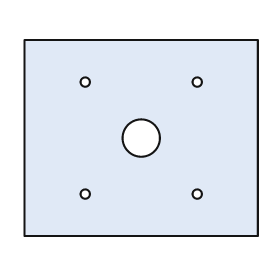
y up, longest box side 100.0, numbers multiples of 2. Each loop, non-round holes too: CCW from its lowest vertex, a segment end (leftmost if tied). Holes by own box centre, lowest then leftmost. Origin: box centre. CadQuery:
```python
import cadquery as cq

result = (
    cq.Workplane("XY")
    .moveTo(-50.0, -42.0)
    .lineTo(50.0, -42.0)
    .lineTo(50.0, 42.0)
    .lineTo(-50.0, 42.0)
    .close()
    .moveTo(-24.0, -24.0)
    .circle(2.0)
    .moveTo(24.0, -24.0)
    .circle(2.0)
    .moveTo(0.0, 0.0)
    .circle(8.0)
    .moveTo(-24.0, 24.0)
    .circle(2.0)
    .moveTo(24.0, 24.0)
    .circle(2.0)
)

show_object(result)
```